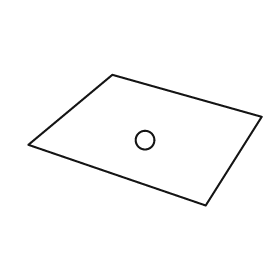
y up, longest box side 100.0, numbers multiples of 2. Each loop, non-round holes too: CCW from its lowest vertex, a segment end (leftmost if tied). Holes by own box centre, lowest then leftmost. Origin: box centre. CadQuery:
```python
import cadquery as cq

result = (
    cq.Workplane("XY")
    .moveTo(26.0, -28.0)
    .lineTo(50.0, 10.0)
    .lineTo(-14.0, 28.0)
    .lineTo(-50.0, -2.0)
    .close()
    .moveTo(0.0, 0.0)
    .circle(4.0)
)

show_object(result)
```